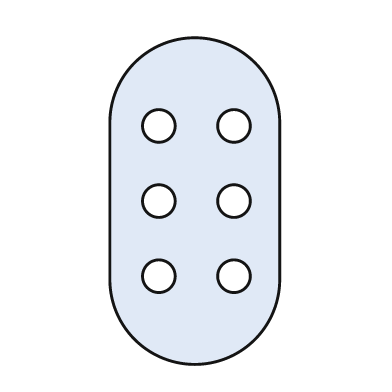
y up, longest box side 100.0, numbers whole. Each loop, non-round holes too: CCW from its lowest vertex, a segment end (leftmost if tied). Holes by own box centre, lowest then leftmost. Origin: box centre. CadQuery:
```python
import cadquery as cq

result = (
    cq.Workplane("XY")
    .moveTo(-26.0, -24.0)
    .threePointArc((0.0, -50.0), (26.0, -24.0))
    .lineTo(26.0, 24.0)
    .threePointArc((0.0, 50.0), (-26.0, 24.0))
    .close()
    .moveTo(-11.0, -23.0)
    .circle(5.0)
    .moveTo(12.0, -23.0)
    .circle(5.0)
    .moveTo(-11.0, 0.0)
    .circle(5.0)
    .moveTo(12.0, 0.0)
    .circle(5.0)
    .moveTo(-11.0, 23.0)
    .circle(5.0)
    .moveTo(12.0, 23.0)
    .circle(5.0)
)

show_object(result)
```